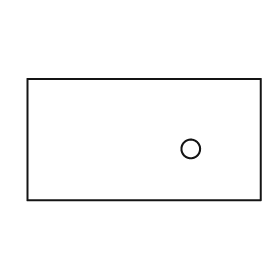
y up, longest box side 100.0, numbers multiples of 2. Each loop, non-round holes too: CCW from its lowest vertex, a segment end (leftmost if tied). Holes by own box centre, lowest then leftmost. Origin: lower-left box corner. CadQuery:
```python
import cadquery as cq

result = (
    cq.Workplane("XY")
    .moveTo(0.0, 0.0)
    .lineTo(100.0, 0.0)
    .lineTo(100.0, 52.0)
    .lineTo(0.0, 52.0)
    .close()
    .moveTo(70.0, 22.0)
    .circle(4.0)
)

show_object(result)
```